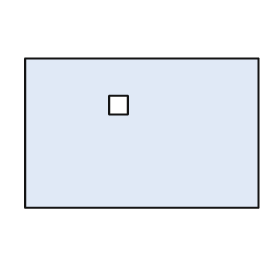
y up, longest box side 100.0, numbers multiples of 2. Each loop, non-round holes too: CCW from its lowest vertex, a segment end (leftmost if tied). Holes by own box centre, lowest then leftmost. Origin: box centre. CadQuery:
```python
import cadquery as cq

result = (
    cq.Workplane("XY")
    .moveTo(-50.0, -32.0)
    .lineTo(50.0, -32.0)
    .lineTo(50.0, 32.0)
    .lineTo(-50.0, 32.0)
    .close()
    .moveTo(-14.0, 8.0)
    .lineTo(-6.0, 8.0)
    .lineTo(-6.0, 16.0)
    .lineTo(-14.0, 16.0)
    .close()
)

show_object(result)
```